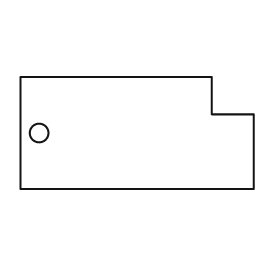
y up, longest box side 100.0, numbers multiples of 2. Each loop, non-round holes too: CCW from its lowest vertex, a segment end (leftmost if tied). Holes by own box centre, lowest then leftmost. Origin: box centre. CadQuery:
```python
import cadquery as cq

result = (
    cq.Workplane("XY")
    .moveTo(-50.0, -24.0)
    .lineTo(50.0, -24.0)
    .lineTo(50.0, 8.0)
    .lineTo(32.0, 8.0)
    .lineTo(32.0, 24.0)
    .lineTo(-50.0, 24.0)
    .close()
    .moveTo(-42.0, 0.0)
    .circle(4.0)
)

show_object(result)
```